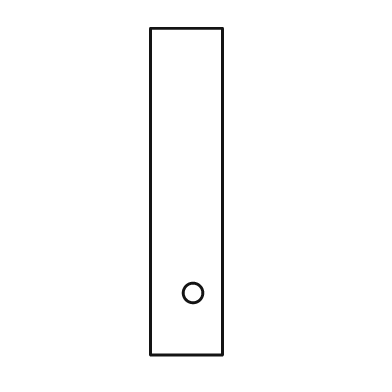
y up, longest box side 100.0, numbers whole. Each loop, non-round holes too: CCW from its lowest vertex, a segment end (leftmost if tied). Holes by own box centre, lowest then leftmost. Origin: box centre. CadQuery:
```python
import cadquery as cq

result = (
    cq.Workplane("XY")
    .moveTo(-11.0, -50.0)
    .lineTo(11.0, -50.0)
    .lineTo(11.0, 50.0)
    .lineTo(-11.0, 50.0)
    .close()
    .moveTo(2.0, -31.0)
    .circle(3.0)
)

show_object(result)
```